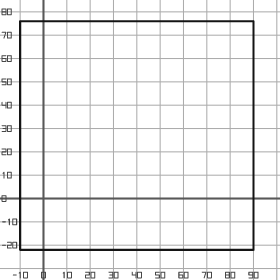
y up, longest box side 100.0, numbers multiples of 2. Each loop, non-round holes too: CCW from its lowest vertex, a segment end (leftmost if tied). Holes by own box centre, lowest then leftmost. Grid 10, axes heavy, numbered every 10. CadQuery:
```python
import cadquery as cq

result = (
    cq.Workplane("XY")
    .moveTo(-10.0, -22.0)
    .lineTo(90.0, -22.0)
    .lineTo(90.0, 76.0)
    .lineTo(-10.0, 76.0)
    .close()
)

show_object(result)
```